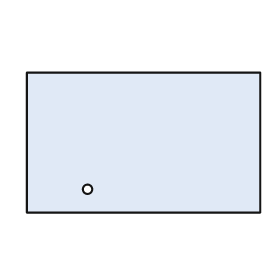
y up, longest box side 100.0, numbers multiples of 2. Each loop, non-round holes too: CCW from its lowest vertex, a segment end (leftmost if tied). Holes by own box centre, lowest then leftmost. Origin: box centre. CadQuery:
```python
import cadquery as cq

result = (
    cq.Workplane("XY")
    .moveTo(-50.0, -30.0)
    .lineTo(50.0, -30.0)
    .lineTo(50.0, 30.0)
    .lineTo(-50.0, 30.0)
    .close()
    .moveTo(-24.0, -20.0)
    .circle(2.0)
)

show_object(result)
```